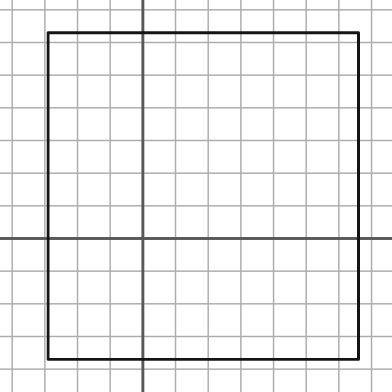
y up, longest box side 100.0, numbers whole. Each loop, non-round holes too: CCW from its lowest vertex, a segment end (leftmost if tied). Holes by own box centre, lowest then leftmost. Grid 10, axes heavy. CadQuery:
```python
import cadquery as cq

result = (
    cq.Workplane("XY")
    .moveTo(-29.0, -37.0)
    .lineTo(66.0, -37.0)
    .lineTo(66.0, 63.0)
    .lineTo(-29.0, 63.0)
    .close()
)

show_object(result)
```